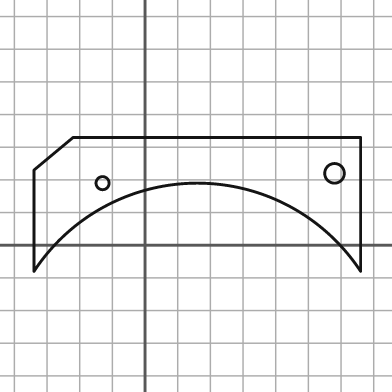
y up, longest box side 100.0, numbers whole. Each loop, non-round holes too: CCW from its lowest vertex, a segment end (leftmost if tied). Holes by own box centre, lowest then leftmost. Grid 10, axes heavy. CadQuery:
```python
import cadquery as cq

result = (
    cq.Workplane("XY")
    .moveTo(-34.0, -8.0)
    .threePointArc((16.0, 19.0), (66.0, -8.0))
    .lineTo(66.0, 33.0)
    .lineTo(-22.0, 33.0)
    .lineTo(-34.0, 23.0)
    .close()
    .moveTo(-13.0, 19.0)
    .circle(2.0)
    .moveTo(58.0, 22.0)
    .circle(3.0)
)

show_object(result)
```